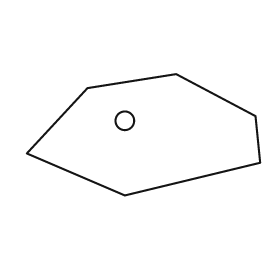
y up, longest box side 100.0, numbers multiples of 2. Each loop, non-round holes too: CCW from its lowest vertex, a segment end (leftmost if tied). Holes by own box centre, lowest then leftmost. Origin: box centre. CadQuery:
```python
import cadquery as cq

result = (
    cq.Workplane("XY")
    .moveTo(-8.0, -26.0)
    .lineTo(50.0, -12.0)
    .lineTo(48.0, 8.0)
    .lineTo(14.0, 26.0)
    .lineTo(-24.0, 20.0)
    .lineTo(-50.0, -8.0)
    .close()
    .moveTo(-8.0, 6.0)
    .circle(4.0)
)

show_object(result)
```